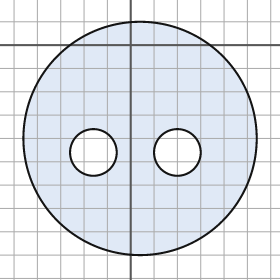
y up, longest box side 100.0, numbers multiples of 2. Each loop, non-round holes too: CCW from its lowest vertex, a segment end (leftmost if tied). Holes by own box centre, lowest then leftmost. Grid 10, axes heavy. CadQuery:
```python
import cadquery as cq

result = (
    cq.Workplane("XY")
    .moveTo(4.0, -40.0)
    .circle(50.0)
    .moveTo(-16.0, -46.0)
    .circle(10.0)
    .moveTo(20.0, -46.0)
    .circle(10.0)
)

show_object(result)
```